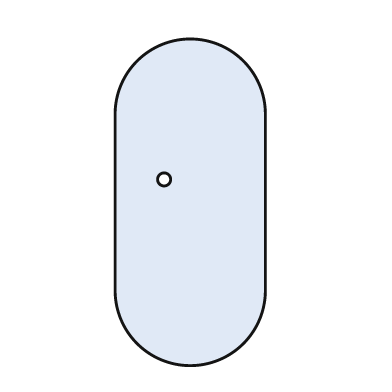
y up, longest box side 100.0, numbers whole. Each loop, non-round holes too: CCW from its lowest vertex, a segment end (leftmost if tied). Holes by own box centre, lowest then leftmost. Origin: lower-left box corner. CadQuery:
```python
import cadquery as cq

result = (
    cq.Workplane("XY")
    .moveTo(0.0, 23.0)
    .threePointArc((23.0, 0.0), (46.0, 23.0))
    .lineTo(46.0, 77.0)
    .threePointArc((23.0, 100.0), (0.0, 77.0))
    .close()
    .moveTo(15.0, 57.0)
    .circle(2.0)
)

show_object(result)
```